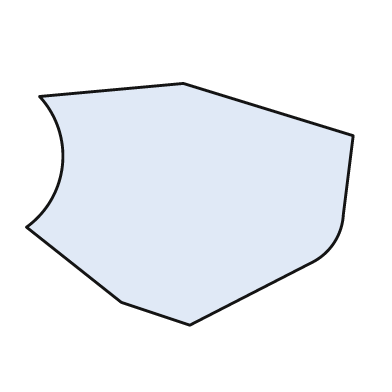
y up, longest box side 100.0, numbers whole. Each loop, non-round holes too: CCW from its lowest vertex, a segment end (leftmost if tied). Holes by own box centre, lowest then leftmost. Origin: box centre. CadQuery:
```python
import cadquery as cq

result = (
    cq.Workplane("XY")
    .moveTo(0.0, -37.0)
    .lineTo(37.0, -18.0)
    .threePointArc((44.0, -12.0), (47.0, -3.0))
    .lineTo(50.0, 21.0)
    .lineTo(-2.0, 37.0)
    .lineTo(-46.0, 33.0)
    .threePointArc((-39.0, 12.0), (-50.0, -7.0))
    .lineTo(-21.0, -30.0)
    .close()
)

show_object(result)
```